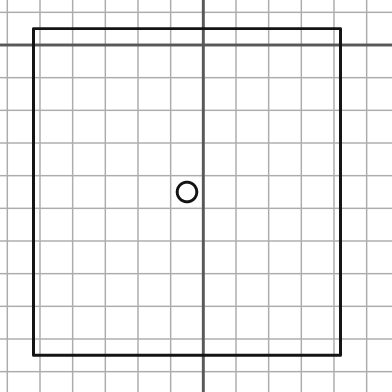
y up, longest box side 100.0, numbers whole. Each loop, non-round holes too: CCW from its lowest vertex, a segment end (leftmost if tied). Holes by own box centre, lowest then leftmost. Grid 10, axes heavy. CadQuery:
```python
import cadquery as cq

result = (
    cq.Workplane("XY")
    .moveTo(-52.0, -95.0)
    .lineTo(42.0, -95.0)
    .lineTo(42.0, 5.0)
    .lineTo(-52.0, 5.0)
    .close()
    .moveTo(-5.0, -45.0)
    .circle(3.0)
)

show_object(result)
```